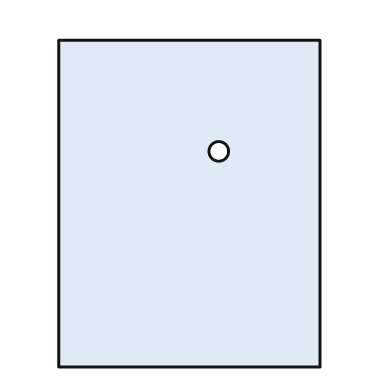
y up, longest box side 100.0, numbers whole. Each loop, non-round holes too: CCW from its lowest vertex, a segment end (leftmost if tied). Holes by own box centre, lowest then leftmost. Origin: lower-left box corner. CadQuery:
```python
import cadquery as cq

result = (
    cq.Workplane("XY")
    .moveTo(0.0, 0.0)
    .lineTo(80.0, 0.0)
    .lineTo(80.0, 100.0)
    .lineTo(0.0, 100.0)
    .close()
    .moveTo(49.0, 66.0)
    .circle(3.0)
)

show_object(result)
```